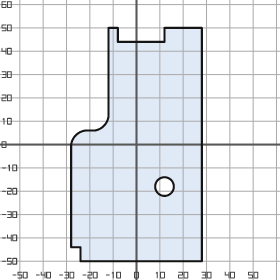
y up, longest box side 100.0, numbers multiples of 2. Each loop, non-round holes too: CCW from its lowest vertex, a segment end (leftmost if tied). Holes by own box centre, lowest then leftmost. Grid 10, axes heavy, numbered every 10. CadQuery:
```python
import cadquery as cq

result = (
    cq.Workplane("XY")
    .moveTo(-24.0, -50.0)
    .lineTo(28.0, -50.0)
    .lineTo(28.0, 50.0)
    .lineTo(12.0, 50.0)
    .lineTo(12.0, 44.0)
    .lineTo(-8.0, 44.0)
    .lineTo(-8.0, 50.0)
    .lineTo(-12.0, 50.0)
    .lineTo(-12.0, 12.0)
    .threePointArc((-14.0, 8.0), (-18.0, 6.0))
    .lineTo(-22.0, 6.0)
    .threePointArc((-26.0, 4.0), (-28.0, 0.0))
    .lineTo(-28.0, -44.0)
    .lineTo(-24.0, -44.0)
    .close()
    .moveTo(12.0, -18.0)
    .circle(4.0)
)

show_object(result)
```